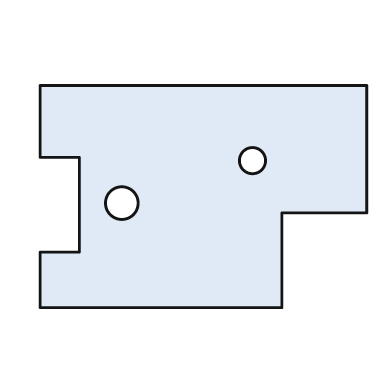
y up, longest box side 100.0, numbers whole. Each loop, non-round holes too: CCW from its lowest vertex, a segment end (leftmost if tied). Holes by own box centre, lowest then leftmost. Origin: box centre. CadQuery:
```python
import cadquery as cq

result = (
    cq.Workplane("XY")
    .moveTo(-50.0, -34.0)
    .lineTo(24.0, -34.0)
    .lineTo(24.0, -5.0)
    .lineTo(50.0, -5.0)
    .lineTo(50.0, 34.0)
    .lineTo(-50.0, 34.0)
    .lineTo(-50.0, 12.0)
    .lineTo(-38.0, 12.0)
    .lineTo(-38.0, -17.0)
    .lineTo(-50.0, -17.0)
    .close()
    .moveTo(-25.0, -2.0)
    .circle(5.0)
    .moveTo(15.0, 11.0)
    .circle(4.0)
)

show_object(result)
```